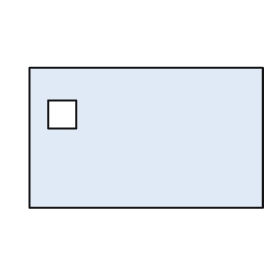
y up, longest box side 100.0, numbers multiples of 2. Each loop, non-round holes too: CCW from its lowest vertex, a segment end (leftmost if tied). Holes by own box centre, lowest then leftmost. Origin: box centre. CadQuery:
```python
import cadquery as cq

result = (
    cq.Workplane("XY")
    .moveTo(-50.0, -30.0)
    .lineTo(50.0, -30.0)
    .lineTo(50.0, 30.0)
    .lineTo(-50.0, 30.0)
    .close()
    .moveTo(-42.0, 4.0)
    .lineTo(-30.0, 4.0)
    .lineTo(-30.0, 16.0)
    .lineTo(-42.0, 16.0)
    .close()
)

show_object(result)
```